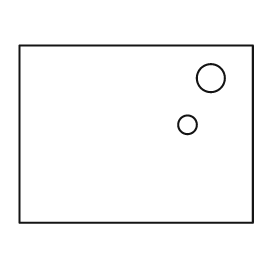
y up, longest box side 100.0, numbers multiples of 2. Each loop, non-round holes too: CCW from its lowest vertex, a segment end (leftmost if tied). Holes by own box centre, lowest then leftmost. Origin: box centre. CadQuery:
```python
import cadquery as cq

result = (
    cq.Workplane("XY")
    .moveTo(-50.0, -38.0)
    .lineTo(50.0, -38.0)
    .lineTo(50.0, 38.0)
    .lineTo(-50.0, 38.0)
    .close()
    .moveTo(22.0, 4.0)
    .circle(4.0)
    .moveTo(32.0, 24.0)
    .circle(6.0)
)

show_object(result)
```